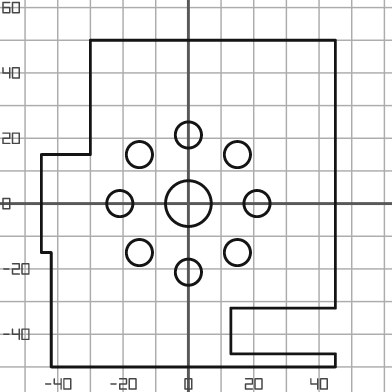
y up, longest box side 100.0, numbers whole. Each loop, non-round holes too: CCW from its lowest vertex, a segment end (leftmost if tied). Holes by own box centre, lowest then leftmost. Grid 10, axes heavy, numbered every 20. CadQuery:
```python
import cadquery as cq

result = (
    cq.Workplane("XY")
    .moveTo(-42.0, -50.0)
    .lineTo(45.0, -50.0)
    .lineTo(45.0, -46.0)
    .lineTo(13.0, -46.0)
    .lineTo(13.0, -32.0)
    .lineTo(45.0, -32.0)
    .lineTo(45.0, 50.0)
    .lineTo(-30.0, 50.0)
    .lineTo(-30.0, 15.0)
    .lineTo(-45.0, 15.0)
    .lineTo(-45.0, -15.0)
    .lineTo(-42.0, -15.0)
    .close()
    .moveTo(0.0, -21.0)
    .circle(4.0)
    .moveTo(-15.0, -15.0)
    .circle(4.0)
    .moveTo(15.0, -15.0)
    .circle(4.0)
    .moveTo(-21.0, 0.0)
    .circle(4.0)
    .moveTo(0.0, 0.0)
    .circle(7.0)
    .moveTo(21.0, 0.0)
    .circle(4.0)
    .moveTo(-15.0, 15.0)
    .circle(4.0)
    .moveTo(15.0, 15.0)
    .circle(4.0)
    .moveTo(0.0, 21.0)
    .circle(4.0)
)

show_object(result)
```